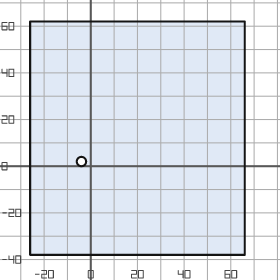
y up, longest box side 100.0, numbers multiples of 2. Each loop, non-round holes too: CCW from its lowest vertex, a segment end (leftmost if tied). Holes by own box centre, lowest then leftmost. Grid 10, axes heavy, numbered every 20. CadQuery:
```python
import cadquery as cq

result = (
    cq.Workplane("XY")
    .moveTo(-26.0, -38.0)
    .lineTo(66.0, -38.0)
    .lineTo(66.0, 62.0)
    .lineTo(-26.0, 62.0)
    .close()
    .moveTo(-4.0, 2.0)
    .circle(2.0)
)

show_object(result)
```